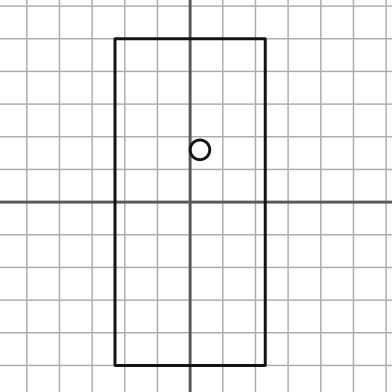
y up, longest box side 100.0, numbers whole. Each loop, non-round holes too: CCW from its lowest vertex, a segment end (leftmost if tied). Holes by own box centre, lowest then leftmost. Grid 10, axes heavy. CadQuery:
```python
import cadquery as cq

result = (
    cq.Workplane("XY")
    .moveTo(-23.0, -50.0)
    .lineTo(23.0, -50.0)
    .lineTo(23.0, 50.0)
    .lineTo(-23.0, 50.0)
    .close()
    .moveTo(3.0, 16.0)
    .circle(3.0)
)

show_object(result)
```